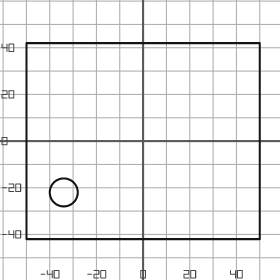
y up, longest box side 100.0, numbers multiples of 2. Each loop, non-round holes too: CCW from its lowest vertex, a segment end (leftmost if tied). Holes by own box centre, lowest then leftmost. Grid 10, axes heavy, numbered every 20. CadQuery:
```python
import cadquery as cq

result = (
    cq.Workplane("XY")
    .moveTo(-50.0, -42.0)
    .lineTo(50.0, -42.0)
    .lineTo(50.0, 42.0)
    .lineTo(-50.0, 42.0)
    .close()
    .moveTo(-34.0, -22.0)
    .circle(6.0)
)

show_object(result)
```